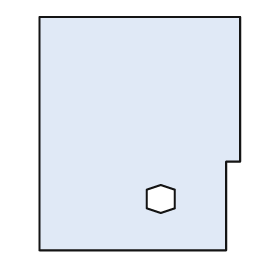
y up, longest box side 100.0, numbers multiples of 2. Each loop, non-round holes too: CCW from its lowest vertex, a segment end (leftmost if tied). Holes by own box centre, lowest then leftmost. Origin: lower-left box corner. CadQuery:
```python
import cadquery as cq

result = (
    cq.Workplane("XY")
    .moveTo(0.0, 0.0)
    .lineTo(80.0, 0.0)
    .lineTo(80.0, 38.0)
    .lineTo(86.0, 38.0)
    .lineTo(86.0, 100.0)
    .lineTo(0.0, 100.0)
    .close()
    .moveTo(52.0, 16.0)
    .lineTo(58.0, 18.0)
    .lineTo(58.0, 26.0)
    .lineTo(52.0, 28.0)
    .lineTo(46.0, 26.0)
    .lineTo(46.0, 18.0)
    .close()
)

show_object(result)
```